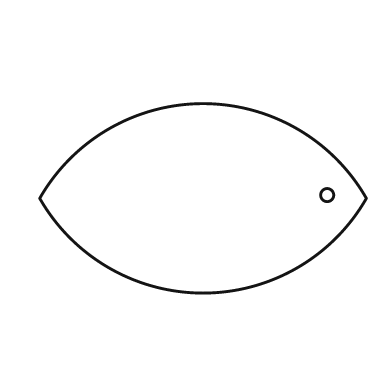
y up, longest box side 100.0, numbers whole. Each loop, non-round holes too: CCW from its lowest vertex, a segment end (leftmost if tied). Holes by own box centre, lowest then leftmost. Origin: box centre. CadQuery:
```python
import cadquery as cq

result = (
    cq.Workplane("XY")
    .moveTo(-50.0, 0.0)
    .threePointArc((0.0, -29.0), (50.0, 0.0))
    .threePointArc((0.0, 29.0), (-50.0, 0.0))
    .close()
    .moveTo(38.0, 1.0)
    .circle(2.0)
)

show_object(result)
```